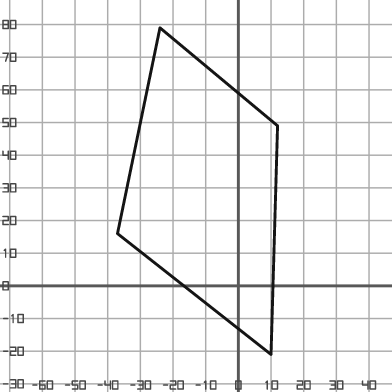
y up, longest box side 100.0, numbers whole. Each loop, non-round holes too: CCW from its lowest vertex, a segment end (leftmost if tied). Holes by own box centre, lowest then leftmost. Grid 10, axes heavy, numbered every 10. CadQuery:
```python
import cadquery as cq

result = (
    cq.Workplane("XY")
    .moveTo(10.0, -21.0)
    .lineTo(12.0, 49.0)
    .lineTo(-24.0, 79.0)
    .lineTo(-37.0, 16.0)
    .close()
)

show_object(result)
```